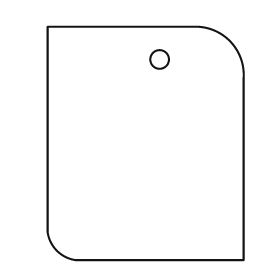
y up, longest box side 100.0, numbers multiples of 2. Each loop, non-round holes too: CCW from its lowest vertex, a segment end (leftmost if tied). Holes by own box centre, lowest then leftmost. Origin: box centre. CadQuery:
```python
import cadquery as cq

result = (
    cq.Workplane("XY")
    .moveTo(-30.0, -50.0)
    .lineTo(42.0, -50.0)
    .lineTo(42.0, 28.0)
    .threePointArc((36.0, 44.0), (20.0, 50.0))
    .lineTo(-42.0, 50.0)
    .lineTo(-42.0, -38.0)
    .threePointArc((-38.0, -46.0), (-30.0, -50.0))
    .close()
    .moveTo(6.0, 36.0)
    .circle(4.0)
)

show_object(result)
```